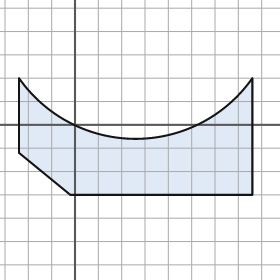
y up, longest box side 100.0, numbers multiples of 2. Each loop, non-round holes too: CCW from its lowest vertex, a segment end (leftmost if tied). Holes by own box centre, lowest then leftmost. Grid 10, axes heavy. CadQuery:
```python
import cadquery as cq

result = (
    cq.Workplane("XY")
    .moveTo(-2.0, -30.0)
    .lineTo(76.0, -30.0)
    .lineTo(76.0, 20.0)
    .threePointArc((26.0, -6.0), (-24.0, 20.0))
    .lineTo(-24.0, -12.0)
    .close()
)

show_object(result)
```